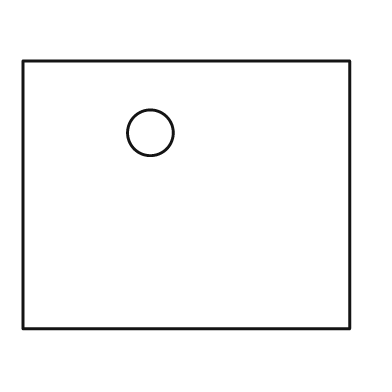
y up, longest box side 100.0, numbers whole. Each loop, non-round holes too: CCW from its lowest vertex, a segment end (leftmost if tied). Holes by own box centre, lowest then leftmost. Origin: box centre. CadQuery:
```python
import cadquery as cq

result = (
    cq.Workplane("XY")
    .moveTo(-50.0, -41.0)
    .lineTo(50.0, -41.0)
    .lineTo(50.0, 41.0)
    .lineTo(-50.0, 41.0)
    .close()
    .moveTo(-11.0, 19.0)
    .circle(7.0)
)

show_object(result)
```